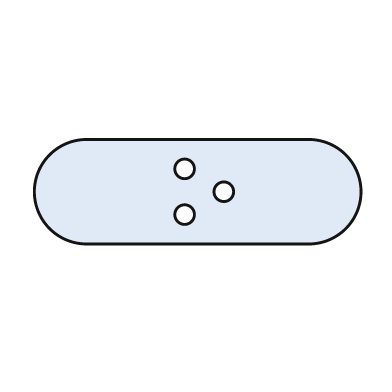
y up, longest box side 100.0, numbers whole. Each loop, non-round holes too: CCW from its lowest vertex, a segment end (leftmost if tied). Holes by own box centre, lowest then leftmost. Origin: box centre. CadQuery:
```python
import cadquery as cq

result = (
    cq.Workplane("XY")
    .moveTo(-34.0, -16.0)
    .lineTo(34.0, -16.0)
    .threePointArc((50.0, 0.0), (34.0, 16.0))
    .lineTo(-34.0, 16.0)
    .threePointArc((-50.0, 0.0), (-34.0, -16.0))
    .close()
    .moveTo(-4.0, -7.0)
    .circle(3.0)
    .moveTo(8.0, 0.0)
    .circle(3.0)
    .moveTo(-4.0, 7.0)
    .circle(3.0)
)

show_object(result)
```